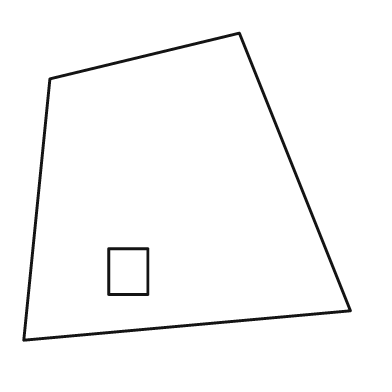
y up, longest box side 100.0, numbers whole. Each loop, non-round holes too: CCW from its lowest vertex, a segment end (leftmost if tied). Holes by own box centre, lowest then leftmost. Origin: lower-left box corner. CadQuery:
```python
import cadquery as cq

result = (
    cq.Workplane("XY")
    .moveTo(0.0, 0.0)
    .lineTo(100.0, 9.0)
    .lineTo(66.0, 94.0)
    .lineTo(8.0, 80.0)
    .close()
    .moveTo(26.0, 14.0)
    .lineTo(38.0, 14.0)
    .lineTo(38.0, 28.0)
    .lineTo(26.0, 28.0)
    .close()
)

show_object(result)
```